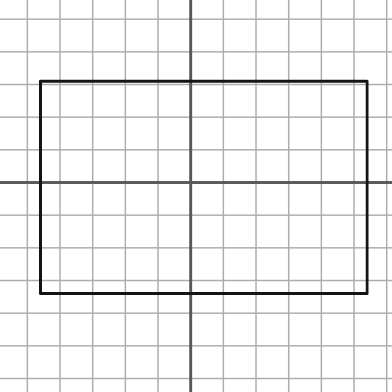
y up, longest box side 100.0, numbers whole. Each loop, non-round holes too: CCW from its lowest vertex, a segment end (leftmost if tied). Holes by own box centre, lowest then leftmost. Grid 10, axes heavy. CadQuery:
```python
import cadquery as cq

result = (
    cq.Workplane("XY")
    .moveTo(-46.0, -34.0)
    .lineTo(54.0, -34.0)
    .lineTo(54.0, 31.0)
    .lineTo(-46.0, 31.0)
    .close()
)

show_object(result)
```